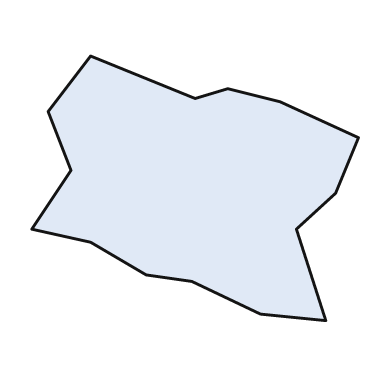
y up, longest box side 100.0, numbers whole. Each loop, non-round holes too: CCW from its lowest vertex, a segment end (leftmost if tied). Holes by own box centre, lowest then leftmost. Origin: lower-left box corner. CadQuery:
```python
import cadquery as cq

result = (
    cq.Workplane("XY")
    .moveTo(90.0, 0.0)
    .lineTo(81.0, 28.0)
    .lineTo(93.0, 39.0)
    .lineTo(100.0, 56.0)
    .lineTo(76.0, 67.0)
    .lineTo(60.0, 71.0)
    .lineTo(50.0, 68.0)
    .lineTo(18.0, 81.0)
    .lineTo(5.0, 64.0)
    .lineTo(12.0, 46.0)
    .lineTo(0.0, 28.0)
    .lineTo(18.0, 24.0)
    .lineTo(35.0, 14.0)
    .lineTo(49.0, 12.0)
    .lineTo(70.0, 2.0)
    .close()
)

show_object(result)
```